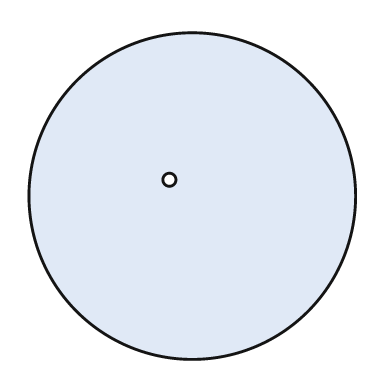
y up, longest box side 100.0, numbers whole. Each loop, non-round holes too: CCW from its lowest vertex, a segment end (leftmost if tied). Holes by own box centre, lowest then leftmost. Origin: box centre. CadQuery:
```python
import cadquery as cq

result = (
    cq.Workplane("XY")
    .moveTo(0.0, 0.0)
    .circle(50.0)
    .moveTo(-7.0, 5.0)
    .circle(2.0)
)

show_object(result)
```